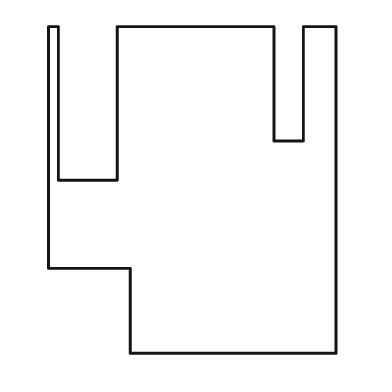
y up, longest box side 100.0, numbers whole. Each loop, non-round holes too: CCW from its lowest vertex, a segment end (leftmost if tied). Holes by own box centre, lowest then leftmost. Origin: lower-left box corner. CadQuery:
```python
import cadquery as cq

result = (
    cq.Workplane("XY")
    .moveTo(25.0, 0.0)
    .lineTo(88.0, 0.0)
    .lineTo(88.0, 100.0)
    .lineTo(78.0, 100.0)
    .lineTo(78.0, 65.0)
    .lineTo(69.0, 65.0)
    .lineTo(69.0, 100.0)
    .lineTo(21.0, 100.0)
    .lineTo(21.0, 53.0)
    .lineTo(3.0, 53.0)
    .lineTo(3.0, 100.0)
    .lineTo(0.0, 100.0)
    .lineTo(0.0, 26.0)
    .lineTo(25.0, 26.0)
    .close()
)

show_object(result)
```